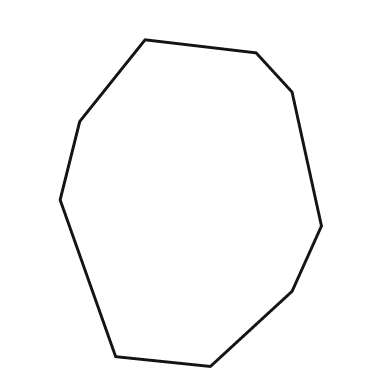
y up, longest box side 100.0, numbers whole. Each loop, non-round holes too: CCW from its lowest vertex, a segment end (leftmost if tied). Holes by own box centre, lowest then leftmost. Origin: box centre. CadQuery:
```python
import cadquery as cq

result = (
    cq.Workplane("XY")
    .moveTo(6.0, -50.0)
    .lineTo(31.0, -27.0)
    .lineTo(40.0, -7.0)
    .lineTo(31.0, 34.0)
    .lineTo(20.0, 46.0)
    .lineTo(-14.0, 50.0)
    .lineTo(-34.0, 25.0)
    .lineTo(-40.0, 1.0)
    .lineTo(-23.0, -47.0)
    .close()
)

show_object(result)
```